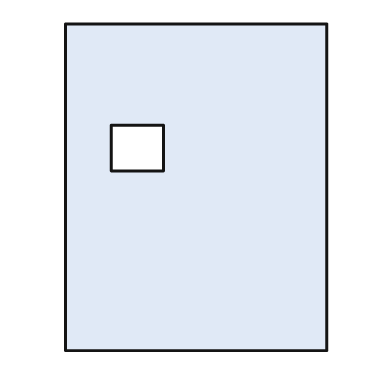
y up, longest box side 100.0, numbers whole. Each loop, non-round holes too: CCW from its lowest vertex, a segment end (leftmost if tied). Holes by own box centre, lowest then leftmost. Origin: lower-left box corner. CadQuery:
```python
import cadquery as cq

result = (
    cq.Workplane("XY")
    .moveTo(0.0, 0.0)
    .lineTo(80.0, 0.0)
    .lineTo(80.0, 100.0)
    .lineTo(0.0, 100.0)
    .close()
    .moveTo(14.0, 55.0)
    .lineTo(30.0, 55.0)
    .lineTo(30.0, 69.0)
    .lineTo(14.0, 69.0)
    .close()
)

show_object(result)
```